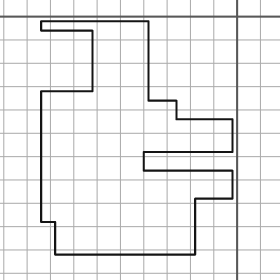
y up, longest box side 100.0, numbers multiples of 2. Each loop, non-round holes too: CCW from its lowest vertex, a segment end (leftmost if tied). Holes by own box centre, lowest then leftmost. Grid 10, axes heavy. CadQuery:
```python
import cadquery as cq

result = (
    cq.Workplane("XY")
    .moveTo(-78.0, -102.0)
    .lineTo(-18.0, -102.0)
    .lineTo(-18.0, -78.0)
    .lineTo(-2.0, -78.0)
    .lineTo(-2.0, -66.0)
    .lineTo(-40.0, -66.0)
    .lineTo(-40.0, -58.0)
    .lineTo(-2.0, -58.0)
    .lineTo(-2.0, -44.0)
    .lineTo(-26.0, -44.0)
    .lineTo(-26.0, -36.0)
    .lineTo(-38.0, -36.0)
    .lineTo(-38.0, -2.0)
    .lineTo(-84.0, -2.0)
    .lineTo(-84.0, -6.0)
    .lineTo(-62.0, -6.0)
    .lineTo(-62.0, -32.0)
    .lineTo(-84.0, -32.0)
    .lineTo(-84.0, -88.0)
    .lineTo(-78.0, -88.0)
    .close()
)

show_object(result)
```